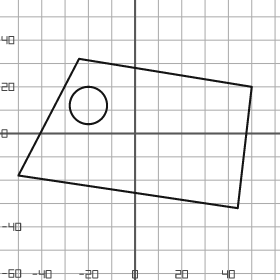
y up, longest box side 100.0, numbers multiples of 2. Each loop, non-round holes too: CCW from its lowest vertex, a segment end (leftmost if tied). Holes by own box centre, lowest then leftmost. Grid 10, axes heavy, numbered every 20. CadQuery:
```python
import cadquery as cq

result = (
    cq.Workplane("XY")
    .moveTo(44.0, -32.0)
    .lineTo(50.0, 20.0)
    .lineTo(-24.0, 32.0)
    .lineTo(-50.0, -18.0)
    .close()
    .moveTo(-20.0, 12.0)
    .circle(8.0)
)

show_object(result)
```